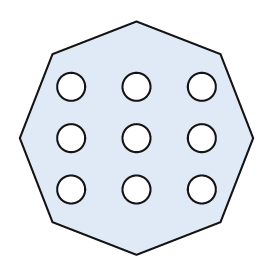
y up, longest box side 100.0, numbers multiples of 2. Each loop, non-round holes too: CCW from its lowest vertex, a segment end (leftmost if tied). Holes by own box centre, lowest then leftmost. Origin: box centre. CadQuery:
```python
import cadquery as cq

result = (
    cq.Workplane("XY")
    .moveTo(0.0, -50.0)
    .lineTo(36.0, -36.0)
    .lineTo(50.0, 0.0)
    .lineTo(36.0, 36.0)
    .lineTo(0.0, 50.0)
    .lineTo(-36.0, 36.0)
    .lineTo(-50.0, 0.0)
    .lineTo(-36.0, -36.0)
    .close()
    .moveTo(-28.0, -22.0)
    .circle(6.0)
    .moveTo(0.0, -22.0)
    .circle(6.0)
    .moveTo(28.0, -22.0)
    .circle(6.0)
    .moveTo(-28.0, 0.0)
    .circle(6.0)
    .moveTo(0.0, 0.0)
    .circle(6.0)
    .moveTo(28.0, 0.0)
    .circle(6.0)
    .moveTo(-28.0, 22.0)
    .circle(6.0)
    .moveTo(0.0, 22.0)
    .circle(6.0)
    .moveTo(28.0, 22.0)
    .circle(6.0)
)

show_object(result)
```